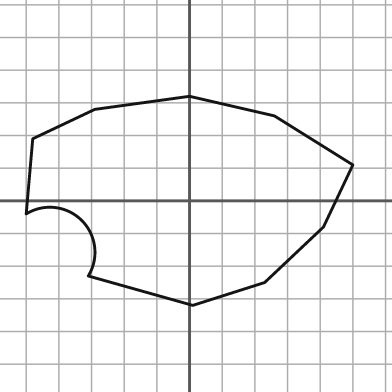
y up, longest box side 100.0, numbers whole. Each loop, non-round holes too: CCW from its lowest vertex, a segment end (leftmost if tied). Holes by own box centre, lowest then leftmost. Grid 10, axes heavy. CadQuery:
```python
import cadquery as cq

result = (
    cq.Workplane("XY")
    .moveTo(1.0, -32.0)
    .lineTo(23.0, -25.0)
    .lineTo(41.0, -8.0)
    .lineTo(50.0, 11.0)
    .lineTo(26.0, 26.0)
    .lineTo(0.0, 32.0)
    .lineTo(-29.0, 28.0)
    .lineTo(-48.0, 19.0)
    .lineTo(-50.0, -4.0)
    .threePointArc((-33.0, -6.0), (-31.0, -23.0))
    .close()
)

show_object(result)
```